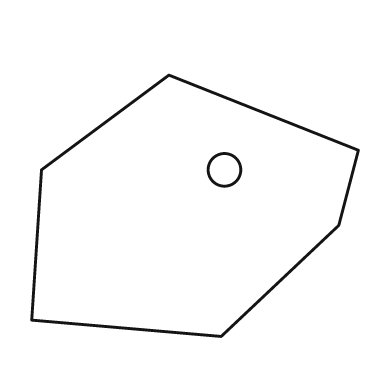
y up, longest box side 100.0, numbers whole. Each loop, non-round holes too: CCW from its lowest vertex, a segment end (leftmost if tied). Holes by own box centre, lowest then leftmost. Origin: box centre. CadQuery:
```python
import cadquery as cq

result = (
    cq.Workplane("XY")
    .moveTo(8.0, -40.0)
    .lineTo(44.0, -6.0)
    .lineTo(50.0, 17.0)
    .lineTo(-8.0, 40.0)
    .lineTo(-47.0, 11.0)
    .lineTo(-50.0, -35.0)
    .close()
    .moveTo(9.0, 11.0)
    .circle(5.0)
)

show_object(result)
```